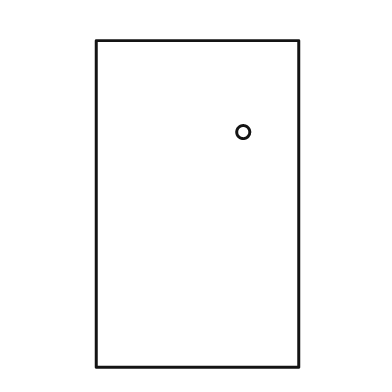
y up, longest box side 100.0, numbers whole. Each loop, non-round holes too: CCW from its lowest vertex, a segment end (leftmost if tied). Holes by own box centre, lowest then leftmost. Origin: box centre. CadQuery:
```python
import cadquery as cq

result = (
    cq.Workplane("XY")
    .moveTo(-31.0, -50.0)
    .lineTo(31.0, -50.0)
    .lineTo(31.0, 50.0)
    .lineTo(-31.0, 50.0)
    .close()
    .moveTo(14.0, 22.0)
    .circle(2.0)
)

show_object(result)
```